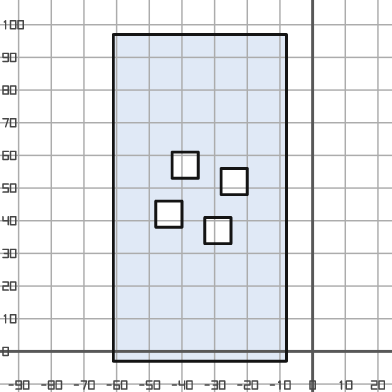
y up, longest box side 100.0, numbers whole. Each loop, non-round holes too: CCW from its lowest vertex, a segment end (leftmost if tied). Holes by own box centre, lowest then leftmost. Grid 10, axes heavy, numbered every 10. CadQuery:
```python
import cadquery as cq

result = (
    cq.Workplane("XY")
    .moveTo(-61.0, -3.0)
    .lineTo(-8.0, -3.0)
    .lineTo(-8.0, 97.0)
    .lineTo(-61.0, 97.0)
    .close()
    .moveTo(-33.0, 33.0)
    .lineTo(-25.0, 33.0)
    .lineTo(-25.0, 41.0)
    .lineTo(-33.0, 41.0)
    .close()
    .moveTo(-48.0, 38.0)
    .lineTo(-40.0, 38.0)
    .lineTo(-40.0, 46.0)
    .lineTo(-48.0, 46.0)
    .close()
    .moveTo(-28.0, 48.0)
    .lineTo(-20.0, 48.0)
    .lineTo(-20.0, 56.0)
    .lineTo(-28.0, 56.0)
    .close()
    .moveTo(-43.0, 53.0)
    .lineTo(-35.0, 53.0)
    .lineTo(-35.0, 61.0)
    .lineTo(-43.0, 61.0)
    .close()
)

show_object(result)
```